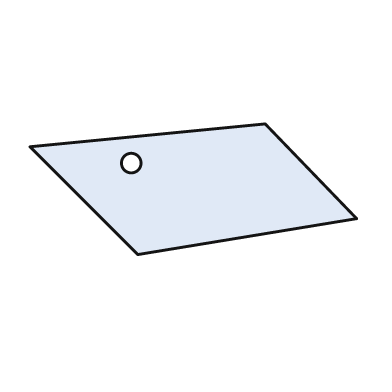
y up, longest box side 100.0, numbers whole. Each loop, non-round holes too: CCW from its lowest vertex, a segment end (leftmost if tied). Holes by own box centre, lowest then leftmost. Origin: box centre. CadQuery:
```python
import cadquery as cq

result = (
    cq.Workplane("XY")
    .moveTo(-17.0, -20.0)
    .lineTo(50.0, -9.0)
    .lineTo(22.0, 20.0)
    .lineTo(-50.0, 13.0)
    .close()
    .moveTo(-19.0, 8.0)
    .circle(3.0)
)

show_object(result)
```